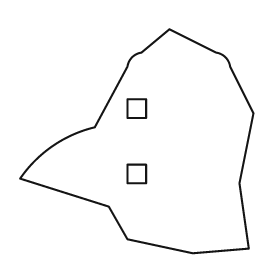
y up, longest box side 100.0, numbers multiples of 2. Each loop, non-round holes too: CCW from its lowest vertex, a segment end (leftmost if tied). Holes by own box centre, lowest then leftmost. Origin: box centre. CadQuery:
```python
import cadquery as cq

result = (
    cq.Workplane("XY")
    .moveTo(24.0, -48.0)
    .lineTo(48.0, -46.0)
    .lineTo(44.0, -18.0)
    .lineTo(50.0, 12.0)
    .lineTo(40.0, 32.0)
    .threePointArc((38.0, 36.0), (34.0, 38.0))
    .lineTo(14.0, 48.0)
    .lineTo(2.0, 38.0)
    .threePointArc((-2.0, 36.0), (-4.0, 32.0))
    .lineTo(-18.0, 6.0)
    .threePointArc((-36.0, -2.0), (-50.0, -16.0))
    .lineTo(-12.0, -28.0)
    .lineTo(-4.0, -42.0)
    .close()
    .moveTo(-4.0, -18.0)
    .lineTo(4.0, -18.0)
    .lineTo(4.0, -10.0)
    .lineTo(-4.0, -10.0)
    .close()
    .moveTo(-4.0, 10.0)
    .lineTo(4.0, 10.0)
    .lineTo(4.0, 18.0)
    .lineTo(-4.0, 18.0)
    .close()
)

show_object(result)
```